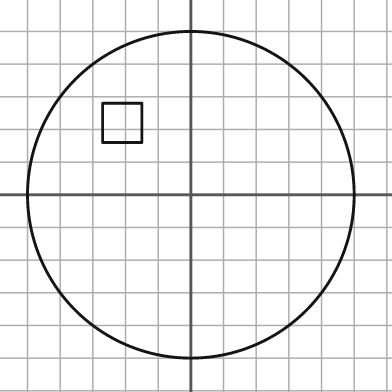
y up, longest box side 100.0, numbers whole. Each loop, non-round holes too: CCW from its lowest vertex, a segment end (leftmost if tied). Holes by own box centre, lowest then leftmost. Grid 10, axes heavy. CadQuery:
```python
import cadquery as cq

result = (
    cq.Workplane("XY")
    .moveTo(0.0, 0.0)
    .circle(50.0)
    .moveTo(-27.0, 16.0)
    .lineTo(-15.0, 16.0)
    .lineTo(-15.0, 28.0)
    .lineTo(-27.0, 28.0)
    .close()
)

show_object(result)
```